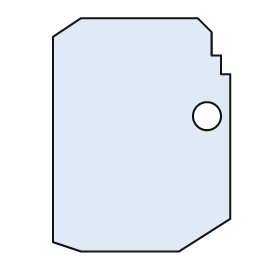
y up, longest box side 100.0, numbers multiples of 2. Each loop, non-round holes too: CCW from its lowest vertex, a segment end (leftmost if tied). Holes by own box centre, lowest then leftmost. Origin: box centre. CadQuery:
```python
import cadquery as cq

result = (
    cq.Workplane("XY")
    .moveTo(-26.0, -50.0)
    .lineTo(16.0, -50.0)
    .lineTo(38.0, -36.0)
    .lineTo(38.0, 26.0)
    .lineTo(34.0, 26.0)
    .lineTo(34.0, 34.0)
    .lineTo(30.0, 34.0)
    .lineTo(30.0, 44.0)
    .lineTo(24.0, 50.0)
    .lineTo(-26.0, 50.0)
    .lineTo(-38.0, 42.0)
    .lineTo(-38.0, -46.0)
    .close()
    .moveTo(28.0, 8.0)
    .circle(6.0)
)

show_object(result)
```